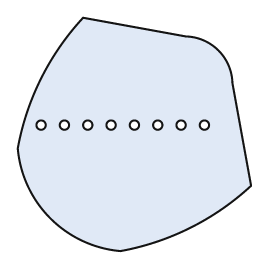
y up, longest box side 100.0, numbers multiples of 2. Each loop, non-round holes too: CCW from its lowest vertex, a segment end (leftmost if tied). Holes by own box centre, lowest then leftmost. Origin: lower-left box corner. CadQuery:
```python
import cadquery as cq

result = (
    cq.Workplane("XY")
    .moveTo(44.0, 0.0)
    .threePointArc((74.0, 10.0), (100.0, 28.0))
    .lineTo(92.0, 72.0)
    .threePointArc((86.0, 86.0), (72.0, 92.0))
    .lineTo(28.0, 100.0)
    .threePointArc((10.0, 74.0), (0.0, 44.0))
    .threePointArc((14.0, 14.0), (44.0, 0.0))
    .close()
    .moveTo(10.0, 54.0)
    .circle(2.0)
    .moveTo(20.0, 54.0)
    .circle(2.0)
    .moveTo(30.0, 54.0)
    .circle(2.0)
    .moveTo(40.0, 54.0)
    .circle(2.0)
    .moveTo(50.0, 54.0)
    .circle(2.0)
    .moveTo(60.0, 54.0)
    .circle(2.0)
    .moveTo(70.0, 54.0)
    .circle(2.0)
    .moveTo(80.0, 54.0)
    .circle(2.0)
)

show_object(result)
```